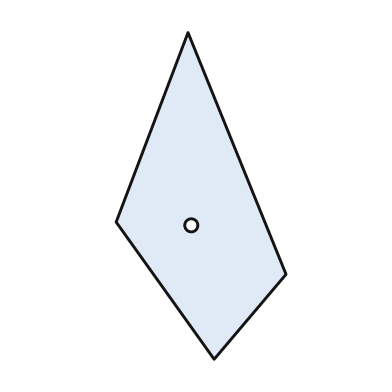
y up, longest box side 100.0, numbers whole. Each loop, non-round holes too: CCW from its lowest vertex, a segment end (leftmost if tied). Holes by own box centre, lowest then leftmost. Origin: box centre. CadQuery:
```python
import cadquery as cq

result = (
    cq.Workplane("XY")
    .moveTo(4.0, -50.0)
    .lineTo(26.0, -24.0)
    .lineTo(-4.0, 50.0)
    .lineTo(-26.0, -8.0)
    .close()
    .moveTo(-3.0, -9.0)
    .circle(2.0)
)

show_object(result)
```